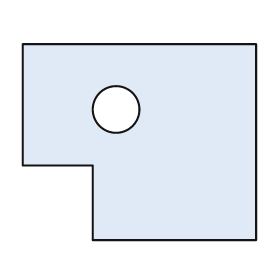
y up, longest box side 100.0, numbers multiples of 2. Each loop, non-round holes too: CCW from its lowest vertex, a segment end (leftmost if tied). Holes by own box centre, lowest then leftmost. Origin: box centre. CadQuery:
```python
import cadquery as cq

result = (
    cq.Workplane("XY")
    .moveTo(-20.0, -42.0)
    .lineTo(50.0, -42.0)
    .lineTo(50.0, 42.0)
    .lineTo(-50.0, 42.0)
    .lineTo(-50.0, -10.0)
    .lineTo(-20.0, -10.0)
    .close()
    .moveTo(-10.0, 14.0)
    .circle(10.0)
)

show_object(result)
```